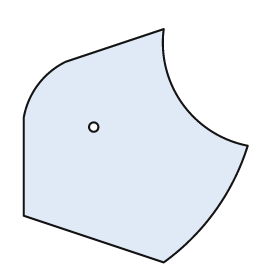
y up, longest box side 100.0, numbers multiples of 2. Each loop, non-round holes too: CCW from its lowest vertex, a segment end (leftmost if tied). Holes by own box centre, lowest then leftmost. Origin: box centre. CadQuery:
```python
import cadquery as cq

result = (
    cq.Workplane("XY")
    .moveTo(12.0, -50.0)
    .threePointArc((34.0, -28.0), (48.0, 0.0))
    .threePointArc((20.0, 18.0), (12.0, 50.0))
    .lineTo(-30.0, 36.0)
    .threePointArc((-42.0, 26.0), (-48.0, 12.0))
    .lineTo(-48.0, -30.0)
    .close()
    .moveTo(-18.0, 8.0)
    .circle(2.0)
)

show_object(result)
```